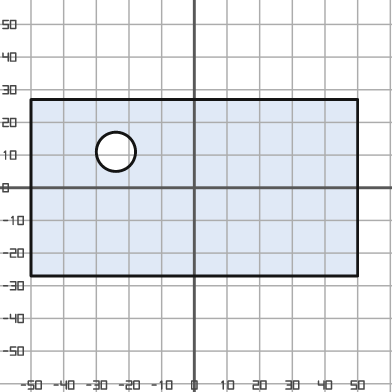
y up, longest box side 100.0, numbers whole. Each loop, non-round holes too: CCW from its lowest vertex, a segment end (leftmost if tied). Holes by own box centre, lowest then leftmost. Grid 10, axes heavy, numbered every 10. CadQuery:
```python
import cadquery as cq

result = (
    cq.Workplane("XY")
    .moveTo(-50.0, -27.0)
    .lineTo(50.0, -27.0)
    .lineTo(50.0, 27.0)
    .lineTo(-50.0, 27.0)
    .close()
    .moveTo(-24.0, 11.0)
    .circle(6.0)
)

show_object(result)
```